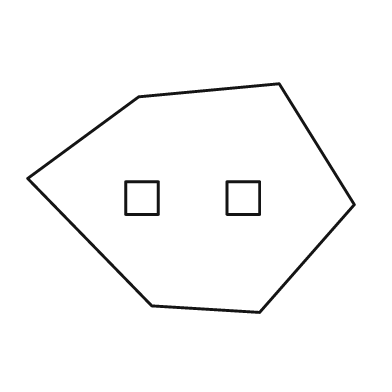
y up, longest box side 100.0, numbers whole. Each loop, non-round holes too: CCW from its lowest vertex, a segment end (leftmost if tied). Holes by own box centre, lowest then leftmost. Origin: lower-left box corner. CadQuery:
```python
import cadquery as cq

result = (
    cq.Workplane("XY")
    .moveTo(71.0, 0.0)
    .lineTo(100.0, 33.0)
    .lineTo(77.0, 70.0)
    .lineTo(34.0, 66.0)
    .lineTo(0.0, 41.0)
    .lineTo(38.0, 2.0)
    .close()
    .moveTo(30.0, 30.0)
    .lineTo(40.0, 30.0)
    .lineTo(40.0, 40.0)
    .lineTo(30.0, 40.0)
    .close()
    .moveTo(61.0, 30.0)
    .lineTo(71.0, 30.0)
    .lineTo(71.0, 40.0)
    .lineTo(61.0, 40.0)
    .close()
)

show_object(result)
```